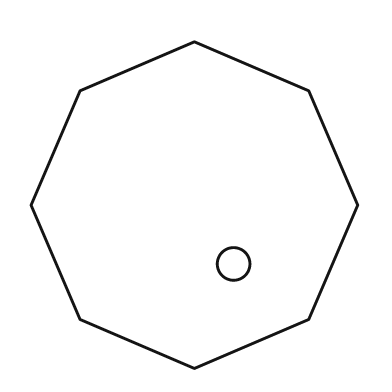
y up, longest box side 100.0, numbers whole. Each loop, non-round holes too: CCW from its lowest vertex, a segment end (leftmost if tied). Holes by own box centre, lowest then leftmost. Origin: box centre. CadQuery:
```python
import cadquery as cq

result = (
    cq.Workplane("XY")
    .moveTo(0.0, -50.0)
    .lineTo(35.0, -35.0)
    .lineTo(50.0, 0.0)
    .lineTo(35.0, 35.0)
    .lineTo(0.0, 50.0)
    .lineTo(-35.0, 35.0)
    .lineTo(-50.0, 0.0)
    .lineTo(-35.0, -35.0)
    .close()
    .moveTo(12.0, -18.0)
    .circle(5.0)
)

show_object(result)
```